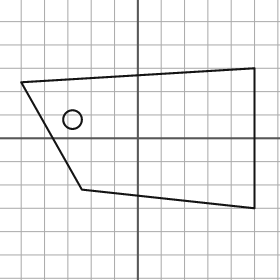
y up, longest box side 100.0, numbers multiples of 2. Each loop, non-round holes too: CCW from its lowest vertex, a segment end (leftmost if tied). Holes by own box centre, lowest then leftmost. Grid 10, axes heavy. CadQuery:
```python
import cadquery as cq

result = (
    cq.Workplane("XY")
    .moveTo(50.0, -30.0)
    .lineTo(50.0, 30.0)
    .lineTo(-50.0, 24.0)
    .lineTo(-24.0, -22.0)
    .close()
    .moveTo(-28.0, 8.0)
    .circle(4.0)
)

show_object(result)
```